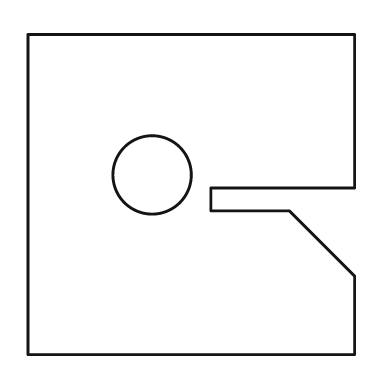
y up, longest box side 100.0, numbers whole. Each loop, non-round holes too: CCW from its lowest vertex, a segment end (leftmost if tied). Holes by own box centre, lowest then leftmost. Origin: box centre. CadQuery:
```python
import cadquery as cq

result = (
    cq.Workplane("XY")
    .moveTo(-50.0, -49.0)
    .lineTo(50.0, -49.0)
    .lineTo(50.0, -25.0)
    .lineTo(30.0, -5.0)
    .lineTo(6.0, -5.0)
    .lineTo(6.0, 2.0)
    .lineTo(50.0, 2.0)
    .lineTo(50.0, 49.0)
    .lineTo(-50.0, 49.0)
    .close()
    .moveTo(-12.0, 6.0)
    .circle(12.0)
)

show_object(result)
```